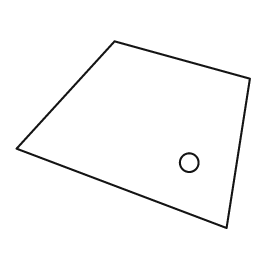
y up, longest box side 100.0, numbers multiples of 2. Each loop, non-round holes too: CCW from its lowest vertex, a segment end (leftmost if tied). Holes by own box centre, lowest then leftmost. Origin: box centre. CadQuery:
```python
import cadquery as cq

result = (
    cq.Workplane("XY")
    .moveTo(40.0, -40.0)
    .lineTo(50.0, 24.0)
    .lineTo(-8.0, 40.0)
    .lineTo(-50.0, -6.0)
    .close()
    .moveTo(24.0, -12.0)
    .circle(4.0)
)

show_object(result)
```